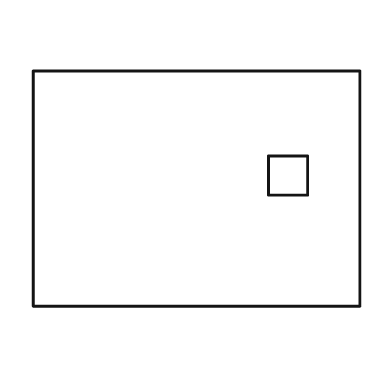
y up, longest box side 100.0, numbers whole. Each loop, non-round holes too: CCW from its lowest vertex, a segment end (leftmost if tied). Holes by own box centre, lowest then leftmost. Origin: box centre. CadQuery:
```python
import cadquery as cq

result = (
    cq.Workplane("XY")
    .moveTo(-50.0, -36.0)
    .lineTo(50.0, -36.0)
    .lineTo(50.0, 36.0)
    .lineTo(-50.0, 36.0)
    .close()
    .moveTo(22.0, -2.0)
    .lineTo(34.0, -2.0)
    .lineTo(34.0, 10.0)
    .lineTo(22.0, 10.0)
    .close()
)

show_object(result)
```